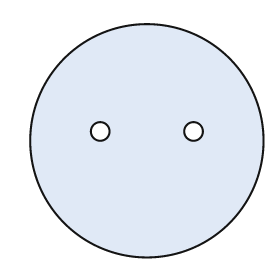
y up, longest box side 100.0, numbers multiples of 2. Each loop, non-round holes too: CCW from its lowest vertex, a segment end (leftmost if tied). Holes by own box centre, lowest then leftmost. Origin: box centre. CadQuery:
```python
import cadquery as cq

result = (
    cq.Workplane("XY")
    .moveTo(0.0, 0.0)
    .circle(50.0)
    .moveTo(-20.0, 4.0)
    .circle(4.0)
    .moveTo(20.0, 4.0)
    .circle(4.0)
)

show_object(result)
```